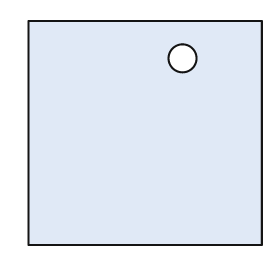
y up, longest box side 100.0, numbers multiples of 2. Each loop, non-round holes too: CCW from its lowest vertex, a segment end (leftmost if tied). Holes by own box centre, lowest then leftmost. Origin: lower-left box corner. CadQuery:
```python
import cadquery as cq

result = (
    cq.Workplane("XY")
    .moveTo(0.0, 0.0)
    .lineTo(100.0, 0.0)
    .lineTo(100.0, 96.0)
    .lineTo(0.0, 96.0)
    .close()
    .moveTo(66.0, 80.0)
    .circle(6.0)
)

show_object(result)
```